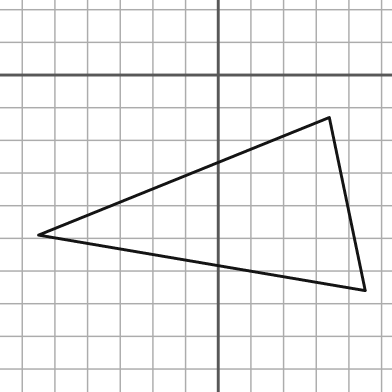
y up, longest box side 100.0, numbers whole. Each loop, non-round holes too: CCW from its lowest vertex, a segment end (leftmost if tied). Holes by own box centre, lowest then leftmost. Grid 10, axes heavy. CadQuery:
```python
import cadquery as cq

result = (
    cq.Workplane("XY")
    .moveTo(45.0, -66.0)
    .lineTo(34.0, -13.0)
    .lineTo(-55.0, -49.0)
    .close()
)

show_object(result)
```